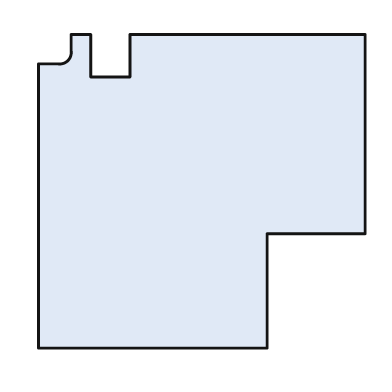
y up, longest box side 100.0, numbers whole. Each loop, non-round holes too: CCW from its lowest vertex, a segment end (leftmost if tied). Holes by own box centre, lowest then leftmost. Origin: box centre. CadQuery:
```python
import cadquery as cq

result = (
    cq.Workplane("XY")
    .moveTo(-50.0, -48.0)
    .lineTo(20.0, -48.0)
    .lineTo(20.0, -13.0)
    .lineTo(50.0, -13.0)
    .lineTo(50.0, 48.0)
    .lineTo(-22.0, 48.0)
    .lineTo(-22.0, 35.0)
    .lineTo(-34.0, 35.0)
    .lineTo(-34.0, 48.0)
    .lineTo(-40.0, 48.0)
    .lineTo(-40.0, 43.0)
    .threePointArc((-41.0, 40.0), (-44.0, 39.0))
    .lineTo(-50.0, 39.0)
    .close()
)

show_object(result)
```